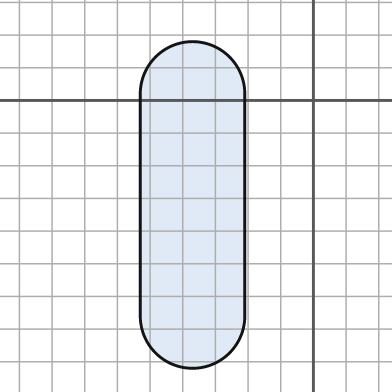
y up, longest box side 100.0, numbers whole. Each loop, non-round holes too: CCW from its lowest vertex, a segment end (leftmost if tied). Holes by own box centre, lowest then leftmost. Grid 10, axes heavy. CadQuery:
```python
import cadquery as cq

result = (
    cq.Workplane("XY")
    .moveTo(-53.0, -66.0)
    .threePointArc((-37.0, -82.0), (-21.0, -66.0))
    .lineTo(-21.0, 2.0)
    .threePointArc((-37.0, 18.0), (-53.0, 2.0))
    .close()
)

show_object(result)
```